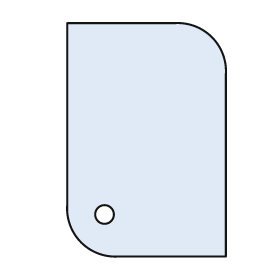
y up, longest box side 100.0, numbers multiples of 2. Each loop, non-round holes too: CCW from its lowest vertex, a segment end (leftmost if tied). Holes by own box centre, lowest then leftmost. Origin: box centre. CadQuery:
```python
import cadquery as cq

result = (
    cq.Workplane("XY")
    .moveTo(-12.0, -50.0)
    .lineTo(34.0, -50.0)
    .lineTo(34.0, 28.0)
    .threePointArc((28.0, 44.0), (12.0, 50.0))
    .lineTo(-34.0, 50.0)
    .lineTo(-34.0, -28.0)
    .threePointArc((-28.0, -44.0), (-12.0, -50.0))
    .close()
    .moveTo(-18.0, -32.0)
    .circle(4.0)
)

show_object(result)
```